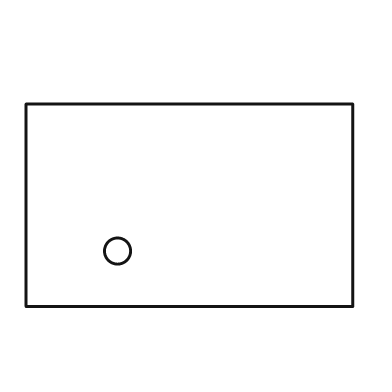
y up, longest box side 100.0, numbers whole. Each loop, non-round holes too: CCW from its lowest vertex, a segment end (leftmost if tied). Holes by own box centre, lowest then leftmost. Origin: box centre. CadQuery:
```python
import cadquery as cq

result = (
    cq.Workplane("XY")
    .moveTo(-50.0, -31.0)
    .lineTo(50.0, -31.0)
    .lineTo(50.0, 31.0)
    .lineTo(-50.0, 31.0)
    .close()
    .moveTo(-22.0, -14.0)
    .circle(4.0)
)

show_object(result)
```